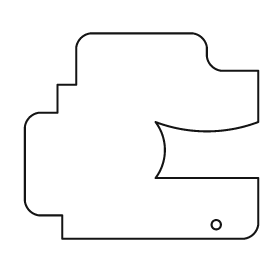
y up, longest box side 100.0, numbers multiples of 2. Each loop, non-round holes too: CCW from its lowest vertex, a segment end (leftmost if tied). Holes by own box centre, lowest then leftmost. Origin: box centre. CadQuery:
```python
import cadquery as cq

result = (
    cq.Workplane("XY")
    .moveTo(-34.0, -44.0)
    .lineTo(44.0, -44.0)
    .threePointArc((48.0, -42.0), (50.0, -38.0))
    .lineTo(50.0, -18.0)
    .lineTo(6.0, -18.0)
    .threePointArc((10.0, -6.0), (6.0, 6.0))
    .threePointArc((28.0, 2.0), (50.0, 6.0))
    .lineTo(50.0, 28.0)
    .lineTo(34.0, 28.0)
    .threePointArc((30.0, 30.0), (28.0, 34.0))
    .lineTo(28.0, 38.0)
    .threePointArc((26.0, 42.0), (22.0, 44.0))
    .lineTo(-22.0, 44.0)
    .threePointArc((-26.0, 42.0), (-28.0, 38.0))
    .lineTo(-28.0, 22.0)
    .lineTo(-36.0, 22.0)
    .lineTo(-36.0, 10.0)
    .lineTo(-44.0, 10.0)
    .threePointArc((-48.0, 8.0), (-50.0, 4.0))
    .lineTo(-50.0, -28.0)
    .threePointArc((-48.0, -32.0), (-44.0, -34.0))
    .lineTo(-34.0, -34.0)
    .close()
    .moveTo(32.0, -38.0)
    .circle(2.0)
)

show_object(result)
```